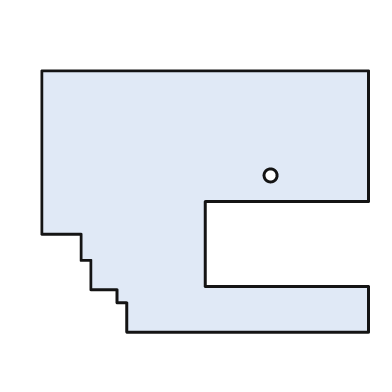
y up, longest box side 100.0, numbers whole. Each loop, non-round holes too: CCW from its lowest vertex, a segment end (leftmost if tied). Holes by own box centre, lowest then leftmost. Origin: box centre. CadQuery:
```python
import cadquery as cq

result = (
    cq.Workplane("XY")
    .moveTo(-24.0, -40.0)
    .lineTo(50.0, -40.0)
    .lineTo(50.0, -26.0)
    .lineTo(0.0, -26.0)
    .lineTo(0.0, 0.0)
    .lineTo(50.0, 0.0)
    .lineTo(50.0, 40.0)
    .lineTo(-50.0, 40.0)
    .lineTo(-50.0, -10.0)
    .lineTo(-38.0, -10.0)
    .lineTo(-38.0, -18.0)
    .lineTo(-35.0, -18.0)
    .lineTo(-35.0, -27.0)
    .lineTo(-27.0, -27.0)
    .lineTo(-27.0, -31.0)
    .lineTo(-24.0, -31.0)
    .close()
    .moveTo(20.0, 8.0)
    .circle(2.0)
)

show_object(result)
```